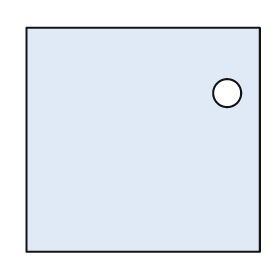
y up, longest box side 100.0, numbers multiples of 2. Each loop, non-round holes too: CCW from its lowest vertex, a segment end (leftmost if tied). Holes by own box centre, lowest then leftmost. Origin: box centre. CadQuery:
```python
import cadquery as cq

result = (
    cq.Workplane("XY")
    .moveTo(-50.0, -48.0)
    .lineTo(50.0, -48.0)
    .lineTo(50.0, 48.0)
    .lineTo(-50.0, 48.0)
    .close()
    .moveTo(36.0, 20.0)
    .circle(6.0)
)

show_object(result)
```